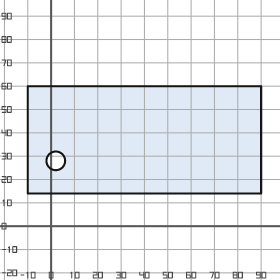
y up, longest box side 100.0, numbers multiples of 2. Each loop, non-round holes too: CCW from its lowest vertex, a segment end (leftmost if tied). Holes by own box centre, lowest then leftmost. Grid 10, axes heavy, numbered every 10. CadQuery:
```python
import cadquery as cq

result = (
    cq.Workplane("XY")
    .moveTo(-10.0, 14.0)
    .lineTo(90.0, 14.0)
    .lineTo(90.0, 60.0)
    .lineTo(-10.0, 60.0)
    .close()
    .moveTo(2.0, 28.0)
    .circle(4.0)
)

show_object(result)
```